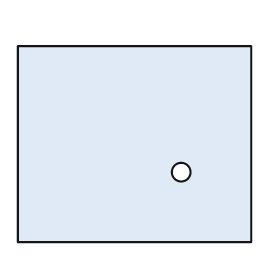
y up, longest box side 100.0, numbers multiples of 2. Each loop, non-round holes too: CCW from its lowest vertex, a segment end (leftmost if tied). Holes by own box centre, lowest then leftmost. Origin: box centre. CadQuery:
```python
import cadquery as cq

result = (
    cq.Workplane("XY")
    .moveTo(-50.0, -42.0)
    .lineTo(50.0, -42.0)
    .lineTo(50.0, 42.0)
    .lineTo(-50.0, 42.0)
    .close()
    .moveTo(20.0, -12.0)
    .circle(4.0)
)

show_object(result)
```